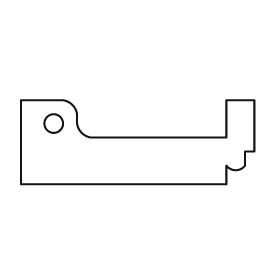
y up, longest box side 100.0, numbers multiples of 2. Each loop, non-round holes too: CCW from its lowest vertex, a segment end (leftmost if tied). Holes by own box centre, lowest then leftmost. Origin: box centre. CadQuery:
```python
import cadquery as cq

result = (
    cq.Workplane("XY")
    .moveTo(-50.0, -18.0)
    .lineTo(38.0, -18.0)
    .lineTo(38.0, -10.0)
    .threePointArc((42.0, -12.0), (46.0, -10.0))
    .lineTo(46.0, -4.0)
    .lineTo(50.0, -4.0)
    .lineTo(50.0, 18.0)
    .lineTo(38.0, 18.0)
    .lineTo(38.0, 2.0)
    .lineTo(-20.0, 2.0)
    .threePointArc((-24.0, 4.0), (-26.0, 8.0))
    .lineTo(-26.0, 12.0)
    .threePointArc((-28.0, 16.0), (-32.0, 18.0))
    .lineTo(-50.0, 18.0)
    .close()
    .moveTo(-36.0, 8.0)
    .circle(4.0)
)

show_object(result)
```